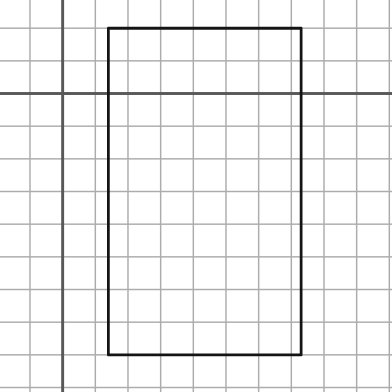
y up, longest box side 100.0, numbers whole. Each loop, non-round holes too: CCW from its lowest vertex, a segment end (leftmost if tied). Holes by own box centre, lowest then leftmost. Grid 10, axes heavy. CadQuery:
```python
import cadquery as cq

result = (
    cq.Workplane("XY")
    .moveTo(14.0, -80.0)
    .lineTo(73.0, -80.0)
    .lineTo(73.0, 20.0)
    .lineTo(14.0, 20.0)
    .close()
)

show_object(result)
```